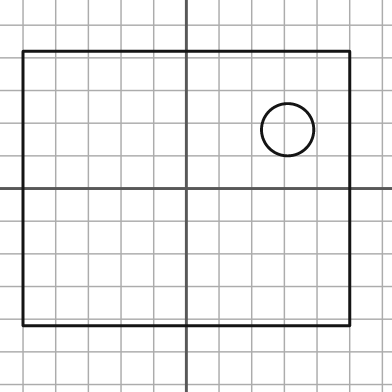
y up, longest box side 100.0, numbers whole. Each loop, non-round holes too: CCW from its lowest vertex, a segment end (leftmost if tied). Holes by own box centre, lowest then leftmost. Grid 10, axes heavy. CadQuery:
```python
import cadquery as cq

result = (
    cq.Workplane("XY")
    .moveTo(-50.0, -42.0)
    .lineTo(50.0, -42.0)
    .lineTo(50.0, 42.0)
    .lineTo(-50.0, 42.0)
    .close()
    .moveTo(31.0, 18.0)
    .circle(8.0)
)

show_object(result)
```